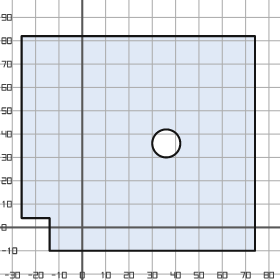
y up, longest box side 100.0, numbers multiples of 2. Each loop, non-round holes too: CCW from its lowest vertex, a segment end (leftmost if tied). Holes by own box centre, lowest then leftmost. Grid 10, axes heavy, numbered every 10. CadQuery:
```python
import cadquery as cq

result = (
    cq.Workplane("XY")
    .moveTo(-14.0, -10.0)
    .lineTo(74.0, -10.0)
    .lineTo(74.0, 82.0)
    .lineTo(-26.0, 82.0)
    .lineTo(-26.0, 4.0)
    .lineTo(-14.0, 4.0)
    .close()
    .moveTo(36.0, 36.0)
    .circle(6.0)
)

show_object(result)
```